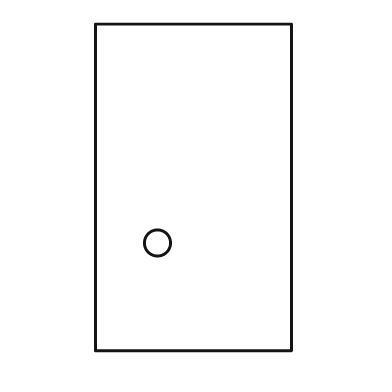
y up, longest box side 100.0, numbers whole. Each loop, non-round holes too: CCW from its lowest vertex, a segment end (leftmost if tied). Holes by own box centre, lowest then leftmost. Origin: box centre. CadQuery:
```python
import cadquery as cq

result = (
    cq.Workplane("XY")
    .moveTo(-30.0, -50.0)
    .lineTo(30.0, -50.0)
    .lineTo(30.0, 50.0)
    .lineTo(-30.0, 50.0)
    .close()
    .moveTo(-11.0, -17.0)
    .circle(4.0)
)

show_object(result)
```